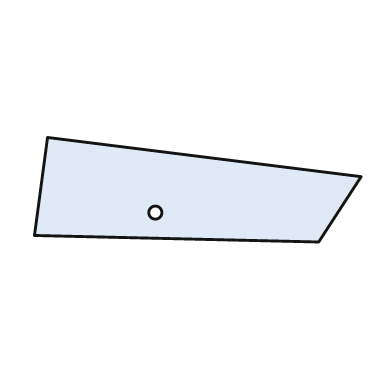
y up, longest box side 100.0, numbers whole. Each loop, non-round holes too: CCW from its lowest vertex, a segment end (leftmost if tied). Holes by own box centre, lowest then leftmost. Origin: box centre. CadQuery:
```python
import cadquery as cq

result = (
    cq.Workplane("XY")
    .moveTo(37.0, -16.0)
    .lineTo(50.0, 4.0)
    .lineTo(-46.0, 16.0)
    .lineTo(-50.0, -14.0)
    .close()
    .moveTo(-13.0, -7.0)
    .circle(2.0)
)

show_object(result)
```